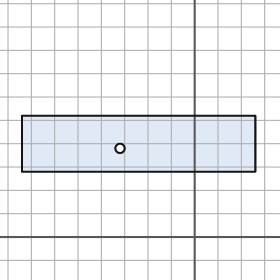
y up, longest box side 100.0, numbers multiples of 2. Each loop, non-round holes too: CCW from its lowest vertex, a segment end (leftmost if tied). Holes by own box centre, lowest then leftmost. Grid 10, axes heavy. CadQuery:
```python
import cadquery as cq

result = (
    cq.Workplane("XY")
    .moveTo(-74.0, 28.0)
    .lineTo(26.0, 28.0)
    .lineTo(26.0, 52.0)
    .lineTo(-74.0, 52.0)
    .close()
    .moveTo(-32.0, 38.0)
    .circle(2.0)
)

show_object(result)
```